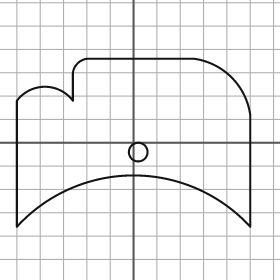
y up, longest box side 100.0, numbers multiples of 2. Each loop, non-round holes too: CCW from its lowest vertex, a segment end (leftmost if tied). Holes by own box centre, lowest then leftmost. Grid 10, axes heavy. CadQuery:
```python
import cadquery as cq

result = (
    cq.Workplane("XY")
    .moveTo(-50.0, -36.0)
    .threePointArc((0.0, -14.0), (50.0, -36.0))
    .lineTo(50.0, 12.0)
    .threePointArc((42.0, 28.0), (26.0, 36.0))
    .lineTo(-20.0, 36.0)
    .threePointArc((-24.0, 34.0), (-26.0, 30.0))
    .lineTo(-26.0, 18.0)
    .threePointArc((-38.0, 24.0), (-50.0, 18.0))
    .close()
    .moveTo(2.0, -4.0)
    .circle(4.0)
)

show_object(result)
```